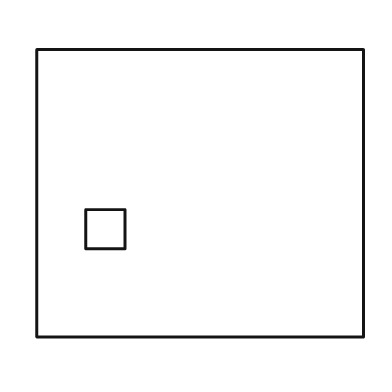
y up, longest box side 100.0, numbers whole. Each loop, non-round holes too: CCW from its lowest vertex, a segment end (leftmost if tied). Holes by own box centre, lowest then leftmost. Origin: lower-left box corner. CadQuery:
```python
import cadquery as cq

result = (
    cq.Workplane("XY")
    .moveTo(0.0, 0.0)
    .lineTo(100.0, 0.0)
    .lineTo(100.0, 88.0)
    .lineTo(0.0, 88.0)
    .close()
    .moveTo(15.0, 27.0)
    .lineTo(27.0, 27.0)
    .lineTo(27.0, 39.0)
    .lineTo(15.0, 39.0)
    .close()
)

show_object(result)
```